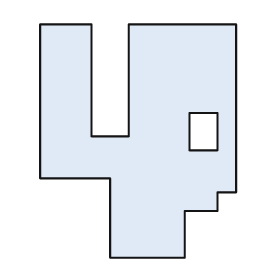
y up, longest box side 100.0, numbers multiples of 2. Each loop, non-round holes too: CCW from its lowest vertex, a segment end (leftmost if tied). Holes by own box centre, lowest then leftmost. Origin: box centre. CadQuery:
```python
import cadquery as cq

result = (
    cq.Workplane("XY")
    .moveTo(-12.0, -50.0)
    .lineTo(20.0, -50.0)
    .lineTo(20.0, -30.0)
    .lineTo(34.0, -30.0)
    .lineTo(34.0, -22.0)
    .lineTo(42.0, -22.0)
    .lineTo(42.0, 50.0)
    .lineTo(-4.0, 50.0)
    .lineTo(-4.0, 2.0)
    .lineTo(-20.0, 2.0)
    .lineTo(-20.0, 50.0)
    .lineTo(-42.0, 50.0)
    .lineTo(-42.0, -16.0)
    .lineTo(-12.0, -16.0)
    .close()
    .moveTo(22.0, -4.0)
    .lineTo(34.0, -4.0)
    .lineTo(34.0, 12.0)
    .lineTo(22.0, 12.0)
    .close()
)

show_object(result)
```